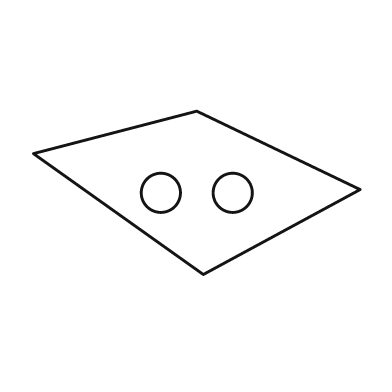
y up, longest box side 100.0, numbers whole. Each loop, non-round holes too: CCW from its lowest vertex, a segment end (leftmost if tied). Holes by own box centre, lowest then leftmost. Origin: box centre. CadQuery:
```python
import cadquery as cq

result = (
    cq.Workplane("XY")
    .moveTo(2.0, -25.0)
    .lineTo(50.0, 1.0)
    .lineTo(0.0, 25.0)
    .lineTo(-50.0, 12.0)
    .close()
    .moveTo(-11.0, 0.0)
    .circle(6.0)
    .moveTo(11.0, 0.0)
    .circle(6.0)
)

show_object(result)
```